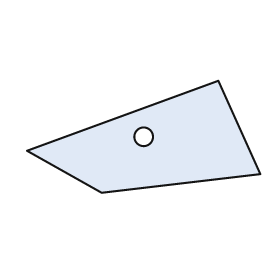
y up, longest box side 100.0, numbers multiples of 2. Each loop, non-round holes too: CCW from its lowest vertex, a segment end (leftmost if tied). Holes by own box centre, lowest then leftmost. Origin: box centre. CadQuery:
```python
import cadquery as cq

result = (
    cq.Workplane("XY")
    .moveTo(-18.0, -24.0)
    .lineTo(50.0, -16.0)
    .lineTo(32.0, 24.0)
    .lineTo(-50.0, -6.0)
    .close()
    .moveTo(0.0, 0.0)
    .circle(4.0)
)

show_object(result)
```